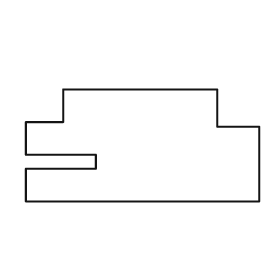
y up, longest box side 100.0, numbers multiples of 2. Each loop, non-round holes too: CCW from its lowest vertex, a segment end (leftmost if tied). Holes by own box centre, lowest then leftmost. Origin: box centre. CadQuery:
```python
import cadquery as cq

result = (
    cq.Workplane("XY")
    .moveTo(-50.0, -24.0)
    .lineTo(50.0, -24.0)
    .lineTo(50.0, 8.0)
    .lineTo(32.0, 8.0)
    .lineTo(32.0, 24.0)
    .lineTo(-34.0, 24.0)
    .lineTo(-34.0, 10.0)
    .lineTo(-50.0, 10.0)
    .lineTo(-50.0, -4.0)
    .lineTo(-20.0, -4.0)
    .lineTo(-20.0, -10.0)
    .lineTo(-50.0, -10.0)
    .close()
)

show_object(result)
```